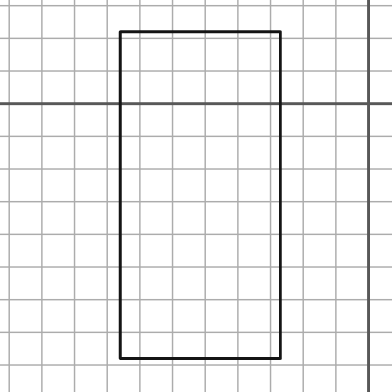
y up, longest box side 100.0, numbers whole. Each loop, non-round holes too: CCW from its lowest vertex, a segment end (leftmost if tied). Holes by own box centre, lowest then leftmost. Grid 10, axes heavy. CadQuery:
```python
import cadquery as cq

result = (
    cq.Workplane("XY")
    .moveTo(-76.0, -78.0)
    .lineTo(-27.0, -78.0)
    .lineTo(-27.0, 22.0)
    .lineTo(-76.0, 22.0)
    .close()
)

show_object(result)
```